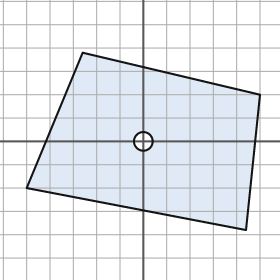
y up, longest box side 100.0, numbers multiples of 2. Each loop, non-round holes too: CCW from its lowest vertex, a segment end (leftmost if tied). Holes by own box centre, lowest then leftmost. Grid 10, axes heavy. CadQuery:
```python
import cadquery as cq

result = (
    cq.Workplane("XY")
    .moveTo(44.0, -38.0)
    .lineTo(50.0, 20.0)
    .lineTo(-26.0, 38.0)
    .lineTo(-50.0, -20.0)
    .close()
    .moveTo(0.0, 0.0)
    .circle(4.0)
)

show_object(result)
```